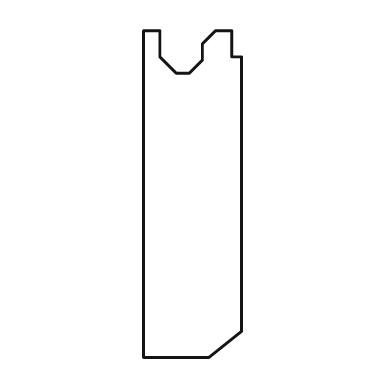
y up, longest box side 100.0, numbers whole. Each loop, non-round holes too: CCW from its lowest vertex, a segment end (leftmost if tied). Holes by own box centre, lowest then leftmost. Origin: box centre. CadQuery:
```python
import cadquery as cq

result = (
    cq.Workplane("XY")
    .moveTo(-15.0, -50.0)
    .lineTo(5.0, -50.0)
    .lineTo(15.0, -42.0)
    .lineTo(15.0, 42.0)
    .lineTo(12.0, 42.0)
    .lineTo(12.0, 50.0)
    .lineTo(7.0, 50.0)
    .lineTo(3.0, 46.0)
    .lineTo(3.0, 41.0)
    .lineTo(-1.0, 37.0)
    .lineTo(-5.0, 37.0)
    .lineTo(-10.0, 42.0)
    .lineTo(-10.0, 50.0)
    .lineTo(-15.0, 50.0)
    .close()
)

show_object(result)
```